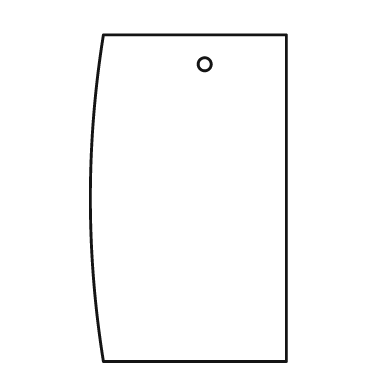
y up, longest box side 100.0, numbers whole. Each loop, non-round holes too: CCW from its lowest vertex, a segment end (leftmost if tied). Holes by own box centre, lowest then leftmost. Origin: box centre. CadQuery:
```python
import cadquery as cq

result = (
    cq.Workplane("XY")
    .moveTo(-26.0, -50.0)
    .lineTo(30.0, -50.0)
    .lineTo(30.0, 50.0)
    .lineTo(-26.0, 50.0)
    .threePointArc((-30.0, 0.0), (-26.0, -50.0))
    .close()
    .moveTo(5.0, 41.0)
    .circle(2.0)
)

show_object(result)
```